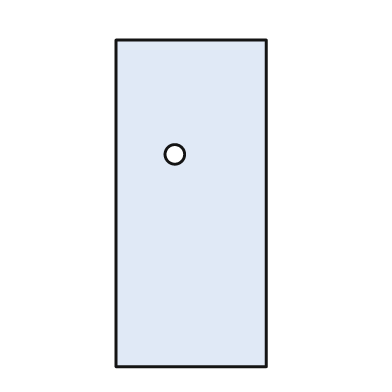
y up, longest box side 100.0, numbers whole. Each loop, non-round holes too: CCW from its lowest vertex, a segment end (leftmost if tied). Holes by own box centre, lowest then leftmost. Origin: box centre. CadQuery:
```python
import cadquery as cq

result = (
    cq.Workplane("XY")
    .moveTo(-23.0, -50.0)
    .lineTo(23.0, -50.0)
    .lineTo(23.0, 50.0)
    .lineTo(-23.0, 50.0)
    .close()
    .moveTo(-5.0, 15.0)
    .circle(3.0)
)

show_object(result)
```